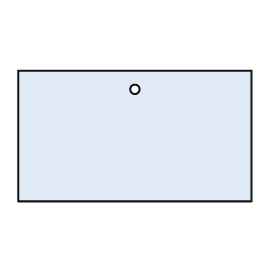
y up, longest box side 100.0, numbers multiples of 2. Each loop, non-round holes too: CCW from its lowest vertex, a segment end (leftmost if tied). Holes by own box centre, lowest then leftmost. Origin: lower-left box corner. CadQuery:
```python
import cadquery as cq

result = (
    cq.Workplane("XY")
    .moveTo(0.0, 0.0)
    .lineTo(100.0, 0.0)
    .lineTo(100.0, 56.0)
    .lineTo(0.0, 56.0)
    .close()
    .moveTo(50.0, 48.0)
    .circle(2.0)
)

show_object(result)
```